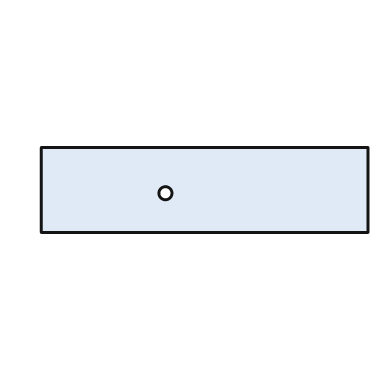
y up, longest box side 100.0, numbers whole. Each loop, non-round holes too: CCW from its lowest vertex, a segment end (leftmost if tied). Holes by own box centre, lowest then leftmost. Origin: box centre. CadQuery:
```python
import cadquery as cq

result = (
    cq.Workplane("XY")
    .moveTo(-50.0, -13.0)
    .lineTo(50.0, -13.0)
    .lineTo(50.0, 13.0)
    .lineTo(-50.0, 13.0)
    .close()
    .moveTo(-12.0, -1.0)
    .circle(2.0)
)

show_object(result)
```